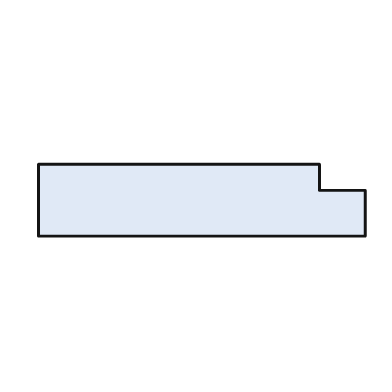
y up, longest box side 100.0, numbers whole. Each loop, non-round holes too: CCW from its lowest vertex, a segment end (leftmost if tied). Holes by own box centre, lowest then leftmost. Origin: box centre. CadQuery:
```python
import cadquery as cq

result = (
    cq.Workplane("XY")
    .moveTo(-50.0, -11.0)
    .lineTo(50.0, -11.0)
    .lineTo(50.0, 3.0)
    .lineTo(36.0, 3.0)
    .lineTo(36.0, 11.0)
    .lineTo(-50.0, 11.0)
    .close()
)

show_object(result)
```